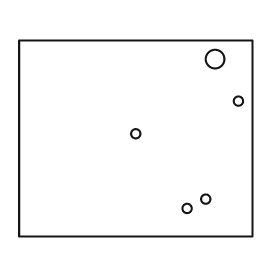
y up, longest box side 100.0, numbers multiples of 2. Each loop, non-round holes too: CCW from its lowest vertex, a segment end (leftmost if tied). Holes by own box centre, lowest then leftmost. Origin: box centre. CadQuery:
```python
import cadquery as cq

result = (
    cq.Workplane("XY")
    .moveTo(-50.0, -42.0)
    .lineTo(50.0, -42.0)
    .lineTo(50.0, 42.0)
    .lineTo(-50.0, 42.0)
    .close()
    .moveTo(22.0, -30.0)
    .circle(2.0)
    .moveTo(30.0, -26.0)
    .circle(2.0)
    .moveTo(0.0, 2.0)
    .circle(2.0)
    .moveTo(44.0, 16.0)
    .circle(2.0)
    .moveTo(34.0, 34.0)
    .circle(4.0)
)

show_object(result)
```